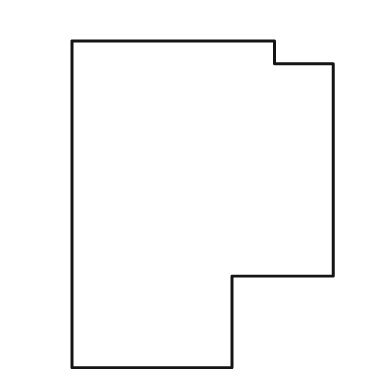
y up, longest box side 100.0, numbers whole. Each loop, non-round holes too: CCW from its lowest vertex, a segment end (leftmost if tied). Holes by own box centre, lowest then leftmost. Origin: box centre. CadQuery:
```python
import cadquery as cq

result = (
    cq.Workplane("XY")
    .moveTo(-40.0, -50.0)
    .lineTo(9.0, -50.0)
    .lineTo(9.0, -22.0)
    .lineTo(40.0, -22.0)
    .lineTo(40.0, 43.0)
    .lineTo(22.0, 43.0)
    .lineTo(22.0, 50.0)
    .lineTo(-40.0, 50.0)
    .close()
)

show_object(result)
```